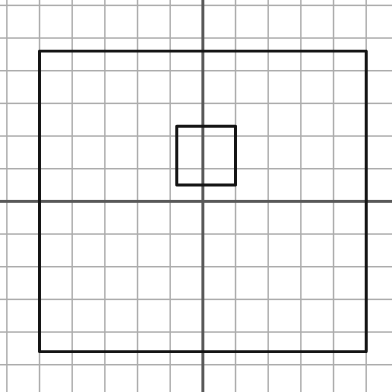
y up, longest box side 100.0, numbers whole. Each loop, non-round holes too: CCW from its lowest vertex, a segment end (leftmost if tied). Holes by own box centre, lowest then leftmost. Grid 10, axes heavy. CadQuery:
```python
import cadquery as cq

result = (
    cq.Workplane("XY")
    .moveTo(-50.0, -46.0)
    .lineTo(50.0, -46.0)
    .lineTo(50.0, 46.0)
    .lineTo(-50.0, 46.0)
    .close()
    .moveTo(-8.0, 5.0)
    .lineTo(10.0, 5.0)
    .lineTo(10.0, 23.0)
    .lineTo(-8.0, 23.0)
    .close()
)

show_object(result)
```